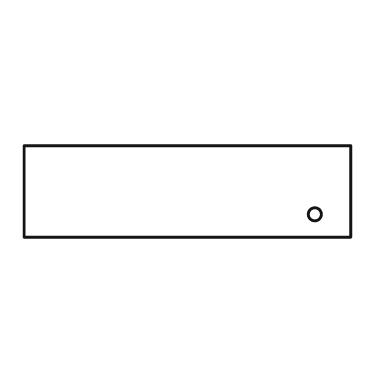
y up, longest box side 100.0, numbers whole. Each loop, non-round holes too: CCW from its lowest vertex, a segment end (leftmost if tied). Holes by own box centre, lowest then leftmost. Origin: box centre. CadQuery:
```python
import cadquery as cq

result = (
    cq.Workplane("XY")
    .moveTo(-50.0, -14.0)
    .lineTo(50.0, -14.0)
    .lineTo(50.0, 14.0)
    .lineTo(-50.0, 14.0)
    .close()
    .moveTo(39.0, -7.0)
    .circle(2.0)
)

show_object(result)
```